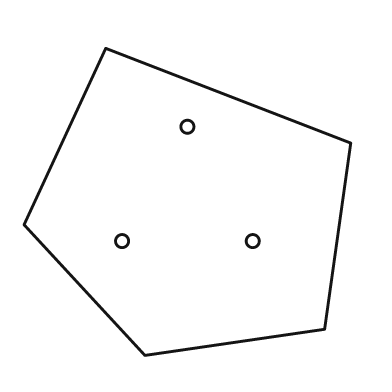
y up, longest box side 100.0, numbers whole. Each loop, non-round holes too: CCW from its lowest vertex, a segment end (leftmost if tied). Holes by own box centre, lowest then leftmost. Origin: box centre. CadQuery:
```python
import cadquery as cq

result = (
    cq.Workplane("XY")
    .moveTo(-13.0, -47.0)
    .lineTo(42.0, -39.0)
    .lineTo(50.0, 18.0)
    .lineTo(-25.0, 47.0)
    .lineTo(-50.0, -7.0)
    .close()
    .moveTo(-20.0, -12.0)
    .circle(2.0)
    .moveTo(20.0, -12.0)
    .circle(2.0)
    .moveTo(0.0, 23.0)
    .circle(2.0)
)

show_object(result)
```